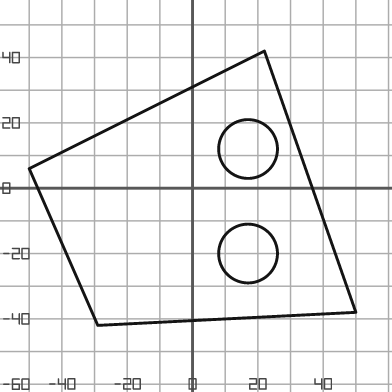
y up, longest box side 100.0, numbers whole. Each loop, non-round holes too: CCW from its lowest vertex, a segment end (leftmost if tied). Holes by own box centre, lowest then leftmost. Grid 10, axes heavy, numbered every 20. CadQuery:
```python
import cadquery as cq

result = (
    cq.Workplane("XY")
    .moveTo(-29.0, -42.0)
    .lineTo(50.0, -38.0)
    .lineTo(22.0, 42.0)
    .lineTo(-50.0, 6.0)
    .close()
    .moveTo(17.0, -20.0)
    .circle(9.0)
    .moveTo(17.0, 12.0)
    .circle(9.0)
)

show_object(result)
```